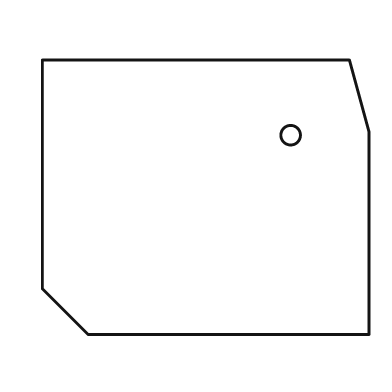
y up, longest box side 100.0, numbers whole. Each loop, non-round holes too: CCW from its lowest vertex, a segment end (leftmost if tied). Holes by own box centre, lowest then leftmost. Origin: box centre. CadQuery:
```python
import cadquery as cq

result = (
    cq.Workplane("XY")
    .moveTo(-36.0, -42.0)
    .lineTo(50.0, -42.0)
    .lineTo(50.0, 20.0)
    .lineTo(44.0, 42.0)
    .lineTo(-50.0, 42.0)
    .lineTo(-50.0, -28.0)
    .close()
    .moveTo(26.0, 19.0)
    .circle(3.0)
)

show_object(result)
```